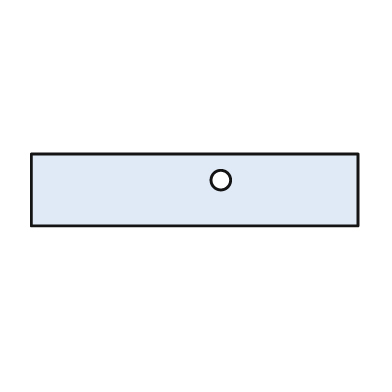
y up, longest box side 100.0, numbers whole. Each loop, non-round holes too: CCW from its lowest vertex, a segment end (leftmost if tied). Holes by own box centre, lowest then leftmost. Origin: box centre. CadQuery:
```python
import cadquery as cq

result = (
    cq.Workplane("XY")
    .moveTo(-50.0, -11.0)
    .lineTo(50.0, -11.0)
    .lineTo(50.0, 11.0)
    .lineTo(-50.0, 11.0)
    .close()
    .moveTo(8.0, 3.0)
    .circle(3.0)
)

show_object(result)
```